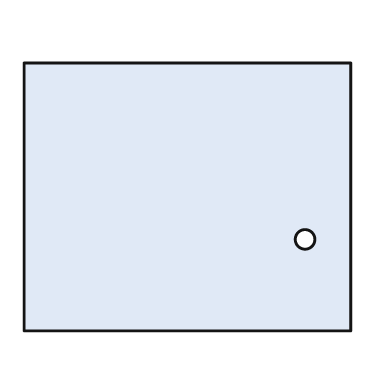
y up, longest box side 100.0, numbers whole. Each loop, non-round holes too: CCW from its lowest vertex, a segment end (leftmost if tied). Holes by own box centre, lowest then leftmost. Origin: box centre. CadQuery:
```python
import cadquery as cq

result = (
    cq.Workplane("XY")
    .moveTo(-50.0, -41.0)
    .lineTo(50.0, -41.0)
    .lineTo(50.0, 41.0)
    .lineTo(-50.0, 41.0)
    .close()
    .moveTo(36.0, -13.0)
    .circle(3.0)
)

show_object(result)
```